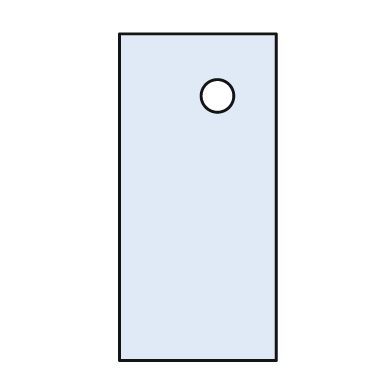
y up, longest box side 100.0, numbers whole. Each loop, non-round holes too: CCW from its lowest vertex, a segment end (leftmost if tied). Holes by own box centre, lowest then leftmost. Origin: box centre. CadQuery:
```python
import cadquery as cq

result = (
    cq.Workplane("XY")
    .moveTo(-24.0, -50.0)
    .lineTo(24.0, -50.0)
    .lineTo(24.0, 50.0)
    .lineTo(-24.0, 50.0)
    .close()
    .moveTo(6.0, 31.0)
    .circle(5.0)
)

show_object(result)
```